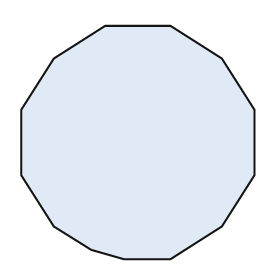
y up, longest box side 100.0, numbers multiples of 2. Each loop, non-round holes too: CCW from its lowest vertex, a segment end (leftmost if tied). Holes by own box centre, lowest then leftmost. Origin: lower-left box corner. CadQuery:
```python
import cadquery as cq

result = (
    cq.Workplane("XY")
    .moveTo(44.0, 0.0)
    .lineTo(64.0, 0.0)
    .lineTo(86.0, 14.0)
    .lineTo(100.0, 36.0)
    .lineTo(100.0, 64.0)
    .lineTo(86.0, 86.0)
    .lineTo(64.0, 100.0)
    .lineTo(36.0, 100.0)
    .lineTo(14.0, 86.0)
    .lineTo(0.0, 64.0)
    .lineTo(0.0, 36.0)
    .lineTo(14.0, 14.0)
    .lineTo(30.0, 4.0)
    .close()
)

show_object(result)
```